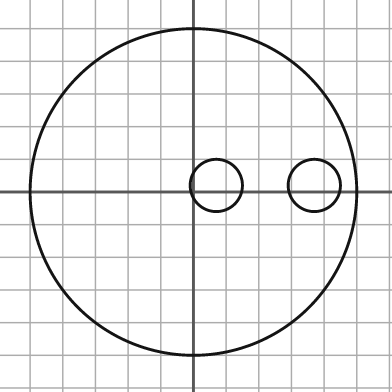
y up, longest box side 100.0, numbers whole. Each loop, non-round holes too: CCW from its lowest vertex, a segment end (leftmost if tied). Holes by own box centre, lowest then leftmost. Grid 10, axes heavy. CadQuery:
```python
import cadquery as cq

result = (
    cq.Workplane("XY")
    .moveTo(0.0, 0.0)
    .circle(50.0)
    .moveTo(7.0, 2.0)
    .circle(8.0)
    .moveTo(37.0, 2.0)
    .circle(8.0)
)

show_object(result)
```